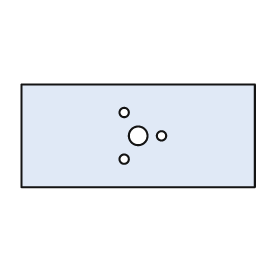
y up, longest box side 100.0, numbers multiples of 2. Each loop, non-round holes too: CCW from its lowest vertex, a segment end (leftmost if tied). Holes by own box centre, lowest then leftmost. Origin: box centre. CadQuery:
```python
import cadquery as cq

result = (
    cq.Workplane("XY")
    .moveTo(-50.0, -22.0)
    .lineTo(50.0, -22.0)
    .lineTo(50.0, 22.0)
    .lineTo(-50.0, 22.0)
    .close()
    .moveTo(-6.0, -10.0)
    .circle(2.0)
    .moveTo(0.0, 0.0)
    .circle(4.0)
    .moveTo(10.0, 0.0)
    .circle(2.0)
    .moveTo(-6.0, 10.0)
    .circle(2.0)
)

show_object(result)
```